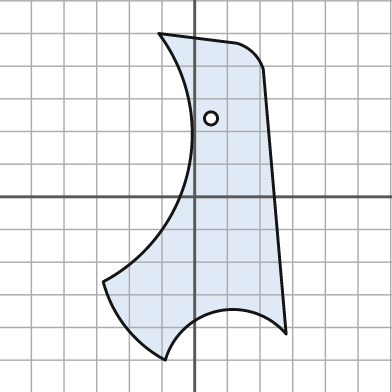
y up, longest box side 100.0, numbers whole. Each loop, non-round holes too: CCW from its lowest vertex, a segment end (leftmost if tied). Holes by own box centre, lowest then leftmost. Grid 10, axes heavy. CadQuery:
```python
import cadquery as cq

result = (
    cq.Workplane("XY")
    .moveTo(-9.0, -50.0)
    .threePointArc((7.0, -35.0), (28.0, -42.0))
    .lineTo(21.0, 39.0)
    .threePointArc((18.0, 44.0), (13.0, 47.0))
    .lineTo(-11.0, 50.0)
    .threePointArc((-2.0, 8.0), (-28.0, -26.0))
    .threePointArc((-21.0, -40.0), (-9.0, -50.0))
    .close()
    .moveTo(5.0, 24.0)
    .circle(2.0)
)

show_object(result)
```